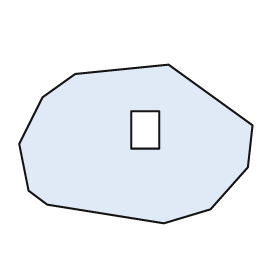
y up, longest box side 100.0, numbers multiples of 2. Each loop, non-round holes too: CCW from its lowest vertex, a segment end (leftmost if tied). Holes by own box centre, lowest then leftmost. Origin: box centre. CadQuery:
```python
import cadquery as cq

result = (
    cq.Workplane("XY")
    .moveTo(12.0, -34.0)
    .lineTo(32.0, -28.0)
    .lineTo(48.0, -10.0)
    .lineTo(50.0, 8.0)
    .lineTo(14.0, 34.0)
    .lineTo(-26.0, 30.0)
    .lineTo(-40.0, 20.0)
    .lineTo(-50.0, 0.0)
    .lineTo(-46.0, -20.0)
    .lineTo(-38.0, -26.0)
    .close()
    .moveTo(-2.0, -2.0)
    .lineTo(10.0, -2.0)
    .lineTo(10.0, 14.0)
    .lineTo(-2.0, 14.0)
    .close()
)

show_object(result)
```